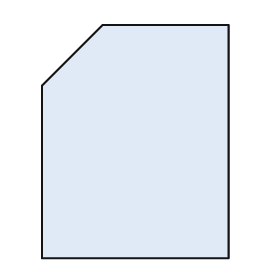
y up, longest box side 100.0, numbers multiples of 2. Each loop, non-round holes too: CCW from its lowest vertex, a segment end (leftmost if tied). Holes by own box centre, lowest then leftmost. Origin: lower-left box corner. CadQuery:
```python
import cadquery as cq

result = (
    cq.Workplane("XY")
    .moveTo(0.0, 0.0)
    .lineTo(80.0, 0.0)
    .lineTo(80.0, 100.0)
    .lineTo(26.0, 100.0)
    .lineTo(0.0, 74.0)
    .close()
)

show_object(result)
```